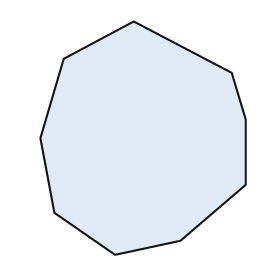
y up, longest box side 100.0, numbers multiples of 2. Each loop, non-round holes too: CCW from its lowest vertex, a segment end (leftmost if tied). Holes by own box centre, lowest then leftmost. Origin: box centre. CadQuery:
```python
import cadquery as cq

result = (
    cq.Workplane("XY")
    .moveTo(-12.0, -50.0)
    .lineTo(16.0, -44.0)
    .lineTo(44.0, -20.0)
    .lineTo(44.0, 8.0)
    .lineTo(38.0, 28.0)
    .lineTo(-4.0, 50.0)
    .lineTo(-34.0, 34.0)
    .lineTo(-44.0, 0.0)
    .lineTo(-38.0, -32.0)
    .close()
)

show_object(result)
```